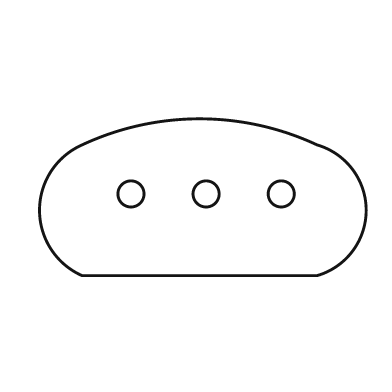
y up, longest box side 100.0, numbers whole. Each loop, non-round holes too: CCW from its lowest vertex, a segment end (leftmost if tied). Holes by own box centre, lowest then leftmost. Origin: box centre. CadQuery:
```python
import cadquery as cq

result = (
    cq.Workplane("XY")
    .moveTo(-37.0, -24.0)
    .lineTo(35.0, -24.0)
    .threePointArc((50.0, -4.0), (35.0, 16.0))
    .threePointArc((-1.0, 24.0), (-37.0, 16.0))
    .threePointArc((-50.0, -4.0), (-37.0, -24.0))
    .close()
    .moveTo(-22.0, 1.0)
    .circle(4.0)
    .moveTo(1.0, 1.0)
    .circle(4.0)
    .moveTo(24.0, 1.0)
    .circle(4.0)
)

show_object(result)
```